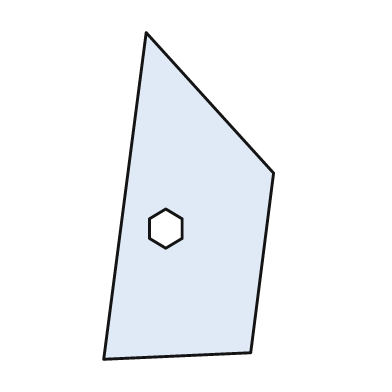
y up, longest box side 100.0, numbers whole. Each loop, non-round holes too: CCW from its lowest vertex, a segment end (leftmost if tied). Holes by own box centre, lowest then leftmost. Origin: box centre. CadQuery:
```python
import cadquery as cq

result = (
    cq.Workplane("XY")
    .moveTo(-26.0, -50.0)
    .lineTo(19.0, -48.0)
    .lineTo(26.0, 7.0)
    .lineTo(-13.0, 50.0)
    .close()
    .moveTo(-7.0, -16.0)
    .lineTo(-2.0, -13.0)
    .lineTo(-2.0, -7.0)
    .lineTo(-7.0, -4.0)
    .lineTo(-12.0, -7.0)
    .lineTo(-12.0, -13.0)
    .close()
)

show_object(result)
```